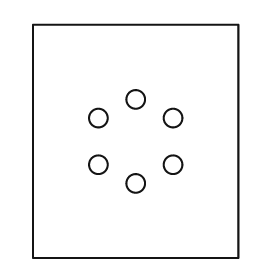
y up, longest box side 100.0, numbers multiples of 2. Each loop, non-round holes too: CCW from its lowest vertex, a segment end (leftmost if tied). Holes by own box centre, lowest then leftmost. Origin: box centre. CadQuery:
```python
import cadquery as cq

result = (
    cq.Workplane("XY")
    .moveTo(-44.0, -50.0)
    .lineTo(44.0, -50.0)
    .lineTo(44.0, 50.0)
    .lineTo(-44.0, 50.0)
    .close()
    .moveTo(0.0, -18.0)
    .circle(4.0)
    .moveTo(-16.0, -10.0)
    .circle(4.0)
    .moveTo(16.0, -10.0)
    .circle(4.0)
    .moveTo(-16.0, 10.0)
    .circle(4.0)
    .moveTo(16.0, 10.0)
    .circle(4.0)
    .moveTo(0.0, 18.0)
    .circle(4.0)
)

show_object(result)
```